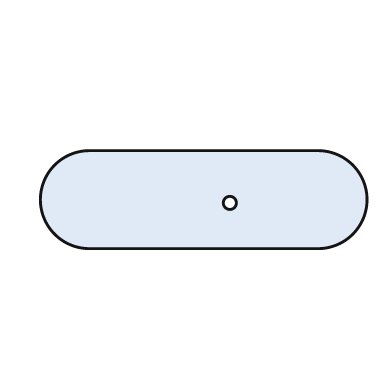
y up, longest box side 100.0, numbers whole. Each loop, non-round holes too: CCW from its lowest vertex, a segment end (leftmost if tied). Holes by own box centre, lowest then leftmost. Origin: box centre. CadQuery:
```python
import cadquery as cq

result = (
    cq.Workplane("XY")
    .moveTo(-35.0, -15.0)
    .lineTo(35.0, -15.0)
    .threePointArc((50.0, 0.0), (35.0, 15.0))
    .lineTo(-35.0, 15.0)
    .threePointArc((-50.0, 0.0), (-35.0, -15.0))
    .close()
    .moveTo(8.0, -1.0)
    .circle(2.0)
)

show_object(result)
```